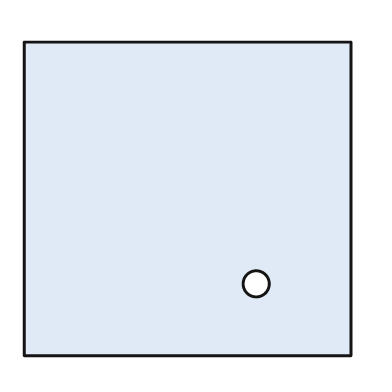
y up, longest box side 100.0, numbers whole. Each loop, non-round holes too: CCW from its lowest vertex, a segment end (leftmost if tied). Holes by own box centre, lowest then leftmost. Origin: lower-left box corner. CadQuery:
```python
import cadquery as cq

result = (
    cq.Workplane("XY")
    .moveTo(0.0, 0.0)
    .lineTo(100.0, 0.0)
    .lineTo(100.0, 96.0)
    .lineTo(0.0, 96.0)
    .close()
    .moveTo(71.0, 22.0)
    .circle(4.0)
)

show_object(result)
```